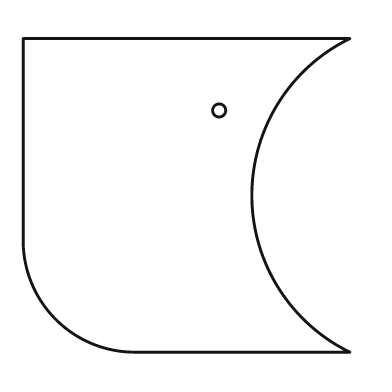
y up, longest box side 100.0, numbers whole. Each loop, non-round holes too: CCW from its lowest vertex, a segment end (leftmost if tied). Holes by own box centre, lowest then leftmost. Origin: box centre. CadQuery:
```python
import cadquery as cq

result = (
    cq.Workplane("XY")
    .moveTo(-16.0, -48.0)
    .lineTo(50.0, -48.0)
    .threePointArc((20.0, 0.0), (50.0, 48.0))
    .lineTo(-50.0, 48.0)
    .lineTo(-50.0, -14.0)
    .threePointArc((-40.0, -38.0), (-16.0, -48.0))
    .close()
    .moveTo(10.0, 26.0)
    .circle(2.0)
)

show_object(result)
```